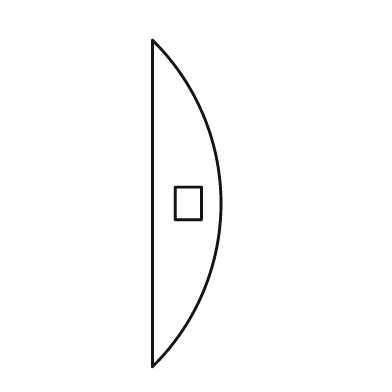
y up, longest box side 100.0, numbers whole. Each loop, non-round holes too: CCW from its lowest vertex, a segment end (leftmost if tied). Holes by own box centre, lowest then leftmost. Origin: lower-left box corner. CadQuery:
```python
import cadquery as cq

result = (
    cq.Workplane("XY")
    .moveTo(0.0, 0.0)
    .threePointArc((21.0, 50.0), (0.0, 100.0))
    .close()
    .moveTo(7.0, 45.0)
    .lineTo(15.0, 45.0)
    .lineTo(15.0, 55.0)
    .lineTo(7.0, 55.0)
    .close()
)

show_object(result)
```